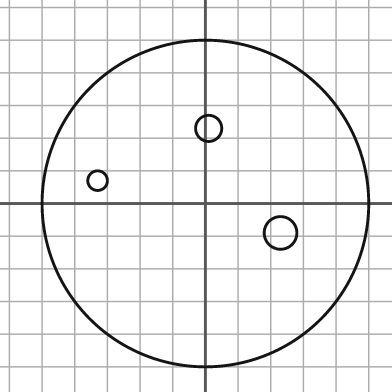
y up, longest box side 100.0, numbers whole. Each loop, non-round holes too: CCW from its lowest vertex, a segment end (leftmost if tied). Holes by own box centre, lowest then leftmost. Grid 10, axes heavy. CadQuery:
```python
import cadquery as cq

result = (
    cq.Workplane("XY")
    .moveTo(0.0, 0.0)
    .circle(50.0)
    .moveTo(23.0, -9.0)
    .circle(5.0)
    .moveTo(-33.0, 7.0)
    .circle(3.0)
    .moveTo(1.0, 23.0)
    .circle(4.0)
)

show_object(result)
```